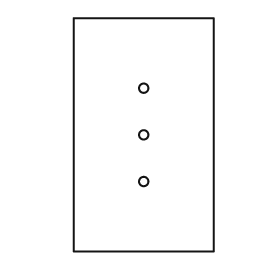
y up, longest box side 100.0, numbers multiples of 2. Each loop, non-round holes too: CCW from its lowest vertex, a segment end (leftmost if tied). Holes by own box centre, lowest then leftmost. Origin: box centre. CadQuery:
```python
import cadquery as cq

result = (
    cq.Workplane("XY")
    .moveTo(-30.0, -50.0)
    .lineTo(30.0, -50.0)
    .lineTo(30.0, 50.0)
    .lineTo(-30.0, 50.0)
    .close()
    .moveTo(0.0, -20.0)
    .circle(2.0)
    .moveTo(0.0, 0.0)
    .circle(2.0)
    .moveTo(0.0, 20.0)
    .circle(2.0)
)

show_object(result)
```